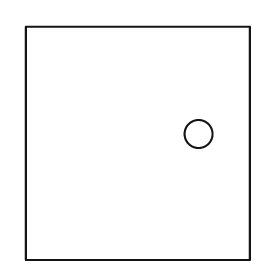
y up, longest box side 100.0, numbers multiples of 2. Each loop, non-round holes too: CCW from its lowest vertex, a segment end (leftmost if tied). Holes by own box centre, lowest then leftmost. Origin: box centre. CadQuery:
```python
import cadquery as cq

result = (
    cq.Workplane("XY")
    .moveTo(-48.0, -50.0)
    .lineTo(48.0, -50.0)
    .lineTo(48.0, 50.0)
    .lineTo(-48.0, 50.0)
    .close()
    .moveTo(26.0, 4.0)
    .circle(6.0)
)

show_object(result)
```